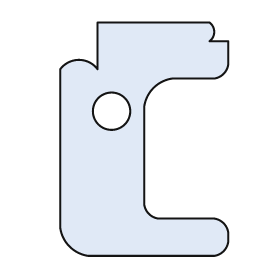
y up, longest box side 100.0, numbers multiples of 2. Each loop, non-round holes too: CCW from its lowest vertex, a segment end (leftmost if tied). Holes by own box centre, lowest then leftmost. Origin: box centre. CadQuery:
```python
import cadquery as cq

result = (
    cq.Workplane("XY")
    .moveTo(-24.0, -50.0)
    .lineTo(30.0, -50.0)
    .threePointArc((34.0, -48.0), (36.0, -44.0))
    .lineTo(36.0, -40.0)
    .threePointArc((34.0, -36.0), (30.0, -34.0))
    .lineTo(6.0, -34.0)
    .threePointArc((2.0, -32.0), (0.0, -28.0))
    .lineTo(0.0, 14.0)
    .threePointArc((4.0, 22.0), (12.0, 26.0))
    .lineTo(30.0, 26.0)
    .threePointArc((34.0, 28.0), (36.0, 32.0))
    .lineTo(36.0, 42.0)
    .lineTo(28.0, 42.0)
    .threePointArc((30.0, 46.0), (28.0, 50.0))
    .lineTo(-20.0, 50.0)
    .lineTo(-20.0, 30.0)
    .threePointArc((-28.0, 34.0), (-36.0, 30.0))
    .lineTo(-36.0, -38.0)
    .threePointArc((-32.0, -46.0), (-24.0, -50.0))
    .close()
    .moveTo(-14.0, 12.0)
    .circle(8.0)
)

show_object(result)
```